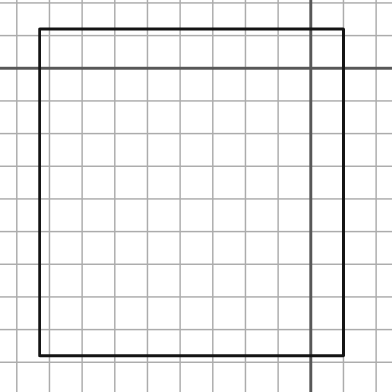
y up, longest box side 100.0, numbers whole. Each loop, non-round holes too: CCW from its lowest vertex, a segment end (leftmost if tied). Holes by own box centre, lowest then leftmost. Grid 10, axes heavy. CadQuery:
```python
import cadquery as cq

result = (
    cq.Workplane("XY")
    .moveTo(-83.0, -88.0)
    .lineTo(10.0, -88.0)
    .lineTo(10.0, 12.0)
    .lineTo(-83.0, 12.0)
    .close()
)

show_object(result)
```